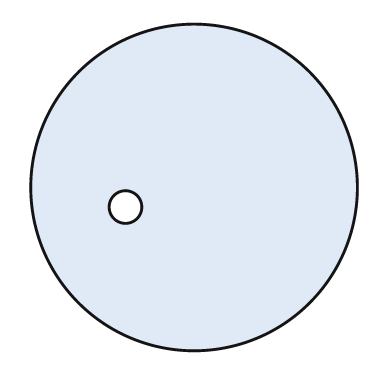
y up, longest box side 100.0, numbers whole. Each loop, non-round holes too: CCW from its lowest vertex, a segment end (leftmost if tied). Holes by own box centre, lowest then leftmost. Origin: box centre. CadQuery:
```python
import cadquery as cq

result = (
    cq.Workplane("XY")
    .moveTo(0.0, 0.0)
    .circle(50.0)
    .moveTo(-21.0, -6.0)
    .circle(5.0)
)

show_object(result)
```